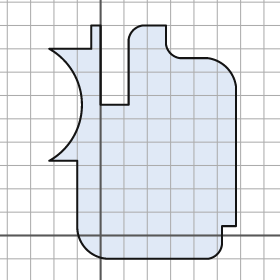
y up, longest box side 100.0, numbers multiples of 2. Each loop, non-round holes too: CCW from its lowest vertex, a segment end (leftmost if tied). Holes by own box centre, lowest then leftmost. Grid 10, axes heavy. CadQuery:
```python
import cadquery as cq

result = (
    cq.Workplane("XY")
    .moveTo(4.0, -10.0)
    .lineTo(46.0, -10.0)
    .threePointArc((50.0, -8.0), (52.0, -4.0))
    .lineTo(52.0, 4.0)
    .lineTo(58.0, 4.0)
    .lineTo(58.0, 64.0)
    .threePointArc((54.0, 72.0), (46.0, 76.0))
    .lineTo(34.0, 76.0)
    .threePointArc((30.0, 78.0), (28.0, 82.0))
    .lineTo(28.0, 90.0)
    .lineTo(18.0, 90.0)
    .threePointArc((14.0, 88.0), (12.0, 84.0))
    .lineTo(12.0, 56.0)
    .lineTo(0.0, 56.0)
    .lineTo(0.0, 90.0)
    .lineTo(-4.0, 90.0)
    .lineTo(-4.0, 80.0)
    .lineTo(-22.0, 80.0)
    .threePointArc((-8.0, 56.0), (-22.0, 32.0))
    .lineTo(-10.0, 32.0)
    .lineTo(-10.0, 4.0)
    .threePointArc((-6.0, -6.0), (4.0, -10.0))
    .close()
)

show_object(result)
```